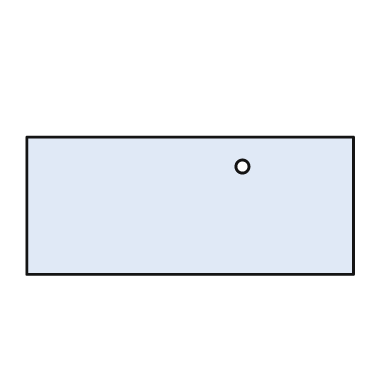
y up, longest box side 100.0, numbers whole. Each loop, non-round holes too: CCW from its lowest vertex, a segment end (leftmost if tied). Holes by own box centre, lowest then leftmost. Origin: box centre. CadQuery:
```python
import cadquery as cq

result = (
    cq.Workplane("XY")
    .moveTo(-50.0, -21.0)
    .lineTo(50.0, -21.0)
    .lineTo(50.0, 21.0)
    .lineTo(-50.0, 21.0)
    .close()
    .moveTo(16.0, 12.0)
    .circle(2.0)
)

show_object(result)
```